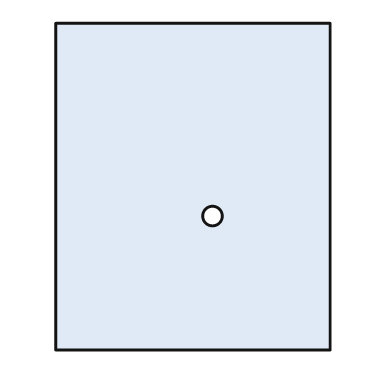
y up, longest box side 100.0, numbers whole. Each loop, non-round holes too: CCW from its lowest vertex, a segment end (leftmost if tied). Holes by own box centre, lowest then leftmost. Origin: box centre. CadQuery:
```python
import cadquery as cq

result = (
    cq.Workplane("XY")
    .moveTo(-42.0, -50.0)
    .lineTo(42.0, -50.0)
    .lineTo(42.0, 50.0)
    .lineTo(-42.0, 50.0)
    .close()
    .moveTo(6.0, -9.0)
    .circle(3.0)
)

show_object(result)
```